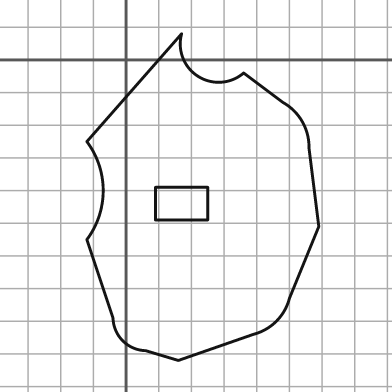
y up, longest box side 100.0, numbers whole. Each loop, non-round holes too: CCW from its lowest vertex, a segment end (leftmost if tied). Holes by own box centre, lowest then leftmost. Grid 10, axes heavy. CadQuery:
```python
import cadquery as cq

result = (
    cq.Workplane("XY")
    .moveTo(16.0, -92.0)
    .lineTo(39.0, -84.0)
    .threePointArc((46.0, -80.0), (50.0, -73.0))
    .lineTo(59.0, -51.0)
    .lineTo(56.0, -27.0)
    .threePointArc((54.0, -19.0), (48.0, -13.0))
    .lineTo(36.0, -4.0)
    .threePointArc((22.0, -5.0), (17.0, 8.0))
    .lineTo(-12.0, -25.0)
    .threePointArc((-7.0, -40.0), (-12.0, -55.0))
    .lineTo(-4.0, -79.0)
    .threePointArc((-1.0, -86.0), (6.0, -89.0))
    .close()
    .moveTo(9.0, -49.0)
    .lineTo(25.0, -49.0)
    .lineTo(25.0, -39.0)
    .lineTo(9.0, -39.0)
    .close()
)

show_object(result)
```